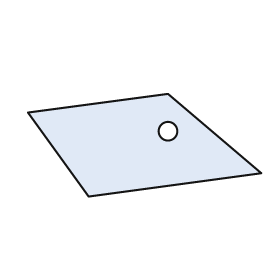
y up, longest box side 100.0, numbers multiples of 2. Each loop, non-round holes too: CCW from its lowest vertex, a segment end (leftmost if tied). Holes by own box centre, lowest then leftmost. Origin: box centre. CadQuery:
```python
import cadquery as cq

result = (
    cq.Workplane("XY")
    .moveTo(-24.0, -22.0)
    .lineTo(50.0, -12.0)
    .lineTo(10.0, 22.0)
    .lineTo(-50.0, 14.0)
    .close()
    .moveTo(10.0, 6.0)
    .circle(4.0)
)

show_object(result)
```